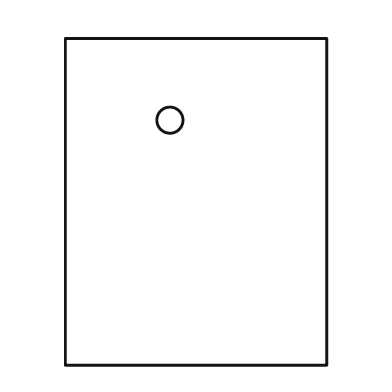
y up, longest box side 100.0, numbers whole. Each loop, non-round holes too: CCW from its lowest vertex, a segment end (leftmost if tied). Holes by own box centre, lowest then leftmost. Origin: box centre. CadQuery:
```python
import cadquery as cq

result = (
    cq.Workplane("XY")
    .moveTo(-40.0, -50.0)
    .lineTo(40.0, -50.0)
    .lineTo(40.0, 50.0)
    .lineTo(-40.0, 50.0)
    .close()
    .moveTo(-8.0, 25.0)
    .circle(4.0)
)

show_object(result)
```